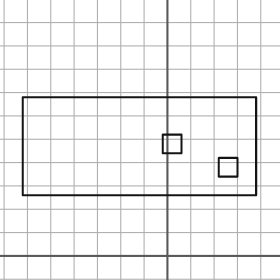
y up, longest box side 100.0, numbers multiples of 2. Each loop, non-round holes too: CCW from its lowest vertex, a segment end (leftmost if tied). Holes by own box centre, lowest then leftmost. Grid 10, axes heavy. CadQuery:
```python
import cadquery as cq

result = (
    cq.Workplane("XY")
    .moveTo(-62.0, 26.0)
    .lineTo(38.0, 26.0)
    .lineTo(38.0, 68.0)
    .lineTo(-62.0, 68.0)
    .close()
    .moveTo(22.0, 34.0)
    .lineTo(30.0, 34.0)
    .lineTo(30.0, 42.0)
    .lineTo(22.0, 42.0)
    .close()
    .moveTo(-2.0, 44.0)
    .lineTo(6.0, 44.0)
    .lineTo(6.0, 52.0)
    .lineTo(-2.0, 52.0)
    .close()
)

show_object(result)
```